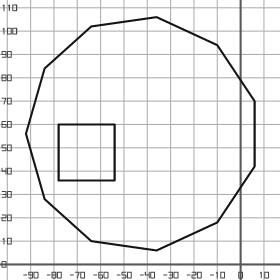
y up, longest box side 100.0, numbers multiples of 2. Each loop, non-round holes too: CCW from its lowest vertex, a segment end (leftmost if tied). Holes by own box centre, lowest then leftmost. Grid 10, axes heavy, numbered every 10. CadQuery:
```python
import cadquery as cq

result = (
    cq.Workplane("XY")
    .moveTo(-36.0, 6.0)
    .lineTo(-10.0, 18.0)
    .lineTo(6.0, 42.0)
    .lineTo(6.0, 70.0)
    .lineTo(-10.0, 94.0)
    .lineTo(-36.0, 106.0)
    .lineTo(-64.0, 102.0)
    .lineTo(-84.0, 84.0)
    .lineTo(-92.0, 56.0)
    .lineTo(-84.0, 28.0)
    .lineTo(-64.0, 10.0)
    .close()
    .moveTo(-78.0, 36.0)
    .lineTo(-54.0, 36.0)
    .lineTo(-54.0, 60.0)
    .lineTo(-78.0, 60.0)
    .close()
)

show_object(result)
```